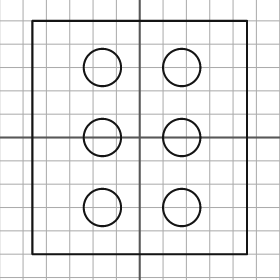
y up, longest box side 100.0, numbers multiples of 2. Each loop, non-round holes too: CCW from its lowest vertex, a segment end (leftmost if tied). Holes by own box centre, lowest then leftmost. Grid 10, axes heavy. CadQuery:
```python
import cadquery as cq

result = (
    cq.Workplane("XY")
    .moveTo(-46.0, -50.0)
    .lineTo(46.0, -50.0)
    .lineTo(46.0, 50.0)
    .lineTo(-46.0, 50.0)
    .close()
    .moveTo(-16.0, -30.0)
    .circle(8.0)
    .moveTo(18.0, -30.0)
    .circle(8.0)
    .moveTo(-16.0, 0.0)
    .circle(8.0)
    .moveTo(18.0, 0.0)
    .circle(8.0)
    .moveTo(-16.0, 30.0)
    .circle(8.0)
    .moveTo(18.0, 30.0)
    .circle(8.0)
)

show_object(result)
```